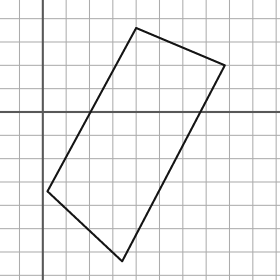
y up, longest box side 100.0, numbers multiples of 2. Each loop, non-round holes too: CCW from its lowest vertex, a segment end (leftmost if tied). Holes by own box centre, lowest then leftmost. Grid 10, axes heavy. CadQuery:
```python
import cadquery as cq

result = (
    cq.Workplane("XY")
    .moveTo(34.0, -64.0)
    .lineTo(78.0, 20.0)
    .lineTo(40.0, 36.0)
    .lineTo(2.0, -34.0)
    .close()
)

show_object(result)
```